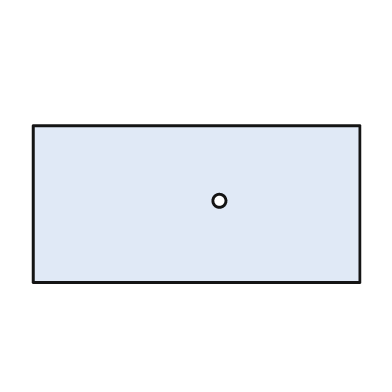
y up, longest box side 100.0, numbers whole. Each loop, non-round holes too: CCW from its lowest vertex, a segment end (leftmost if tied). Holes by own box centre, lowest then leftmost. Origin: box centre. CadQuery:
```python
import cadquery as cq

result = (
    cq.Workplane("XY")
    .moveTo(-50.0, -24.0)
    .lineTo(50.0, -24.0)
    .lineTo(50.0, 24.0)
    .lineTo(-50.0, 24.0)
    .close()
    .moveTo(7.0, 1.0)
    .circle(2.0)
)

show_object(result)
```